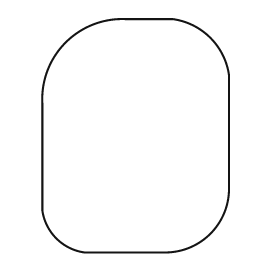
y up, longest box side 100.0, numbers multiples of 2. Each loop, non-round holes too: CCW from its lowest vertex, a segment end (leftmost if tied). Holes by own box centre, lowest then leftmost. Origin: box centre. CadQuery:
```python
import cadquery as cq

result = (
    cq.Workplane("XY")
    .moveTo(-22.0, -50.0)
    .lineTo(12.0, -50.0)
    .threePointArc((32.0, -42.0), (40.0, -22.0))
    .lineTo(40.0, 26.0)
    .threePointArc((32.0, 42.0), (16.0, 50.0))
    .lineTo(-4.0, 50.0)
    .threePointArc((-30.0, 40.0), (-40.0, 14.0))
    .lineTo(-40.0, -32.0)
    .threePointArc((-34.0, -44.0), (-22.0, -50.0))
    .close()
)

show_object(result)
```